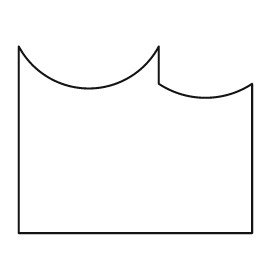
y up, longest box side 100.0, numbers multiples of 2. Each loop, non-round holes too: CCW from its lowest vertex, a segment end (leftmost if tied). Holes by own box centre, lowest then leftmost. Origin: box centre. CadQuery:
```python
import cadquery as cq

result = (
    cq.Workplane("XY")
    .moveTo(-50.0, -40.0)
    .lineTo(50.0, -40.0)
    .lineTo(50.0, 24.0)
    .threePointArc((30.0, 18.0), (10.0, 24.0))
    .lineTo(10.0, 40.0)
    .threePointArc((-20.0, 22.0), (-50.0, 40.0))
    .close()
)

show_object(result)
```